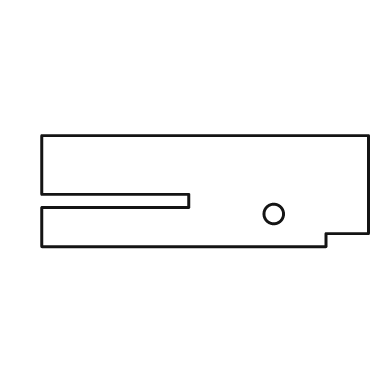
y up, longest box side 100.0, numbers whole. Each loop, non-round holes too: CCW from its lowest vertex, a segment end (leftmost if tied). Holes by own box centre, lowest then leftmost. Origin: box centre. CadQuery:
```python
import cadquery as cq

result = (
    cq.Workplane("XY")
    .moveTo(-50.0, -17.0)
    .lineTo(37.0, -17.0)
    .lineTo(37.0, -13.0)
    .lineTo(50.0, -13.0)
    .lineTo(50.0, 17.0)
    .lineTo(-50.0, 17.0)
    .lineTo(-50.0, -1.0)
    .lineTo(-5.0, -1.0)
    .lineTo(-5.0, -5.0)
    .lineTo(-50.0, -5.0)
    .close()
    .moveTo(21.0, -7.0)
    .circle(3.0)
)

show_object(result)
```